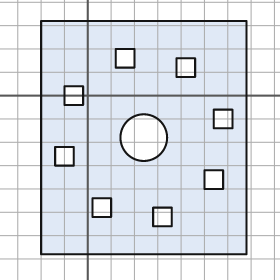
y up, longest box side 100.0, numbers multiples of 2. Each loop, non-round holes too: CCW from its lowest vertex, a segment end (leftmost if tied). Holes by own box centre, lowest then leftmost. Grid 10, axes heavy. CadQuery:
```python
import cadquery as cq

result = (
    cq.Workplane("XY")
    .moveTo(-20.0, -68.0)
    .lineTo(68.0, -68.0)
    .lineTo(68.0, 32.0)
    .lineTo(-20.0, 32.0)
    .close()
    .moveTo(28.0, -56.0)
    .lineTo(36.0, -56.0)
    .lineTo(36.0, -48.0)
    .lineTo(28.0, -48.0)
    .close()
    .moveTo(2.0, -52.0)
    .lineTo(10.0, -52.0)
    .lineTo(10.0, -44.0)
    .lineTo(2.0, -44.0)
    .close()
    .moveTo(50.0, -40.0)
    .lineTo(58.0, -40.0)
    .lineTo(58.0, -32.0)
    .lineTo(50.0, -32.0)
    .close()
    .moveTo(-14.0, -30.0)
    .lineTo(-6.0, -30.0)
    .lineTo(-6.0, -22.0)
    .lineTo(-14.0, -22.0)
    .close()
    .moveTo(24.0, -18.0)
    .circle(10.0)
    .moveTo(54.0, -14.0)
    .lineTo(62.0, -14.0)
    .lineTo(62.0, -6.0)
    .lineTo(54.0, -6.0)
    .close()
    .moveTo(-10.0, -4.0)
    .lineTo(-2.0, -4.0)
    .lineTo(-2.0, 4.0)
    .lineTo(-10.0, 4.0)
    .close()
    .moveTo(38.0, 8.0)
    .lineTo(46.0, 8.0)
    .lineTo(46.0, 16.0)
    .lineTo(38.0, 16.0)
    .close()
    .moveTo(12.0, 12.0)
    .lineTo(20.0, 12.0)
    .lineTo(20.0, 20.0)
    .lineTo(12.0, 20.0)
    .close()
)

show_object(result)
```